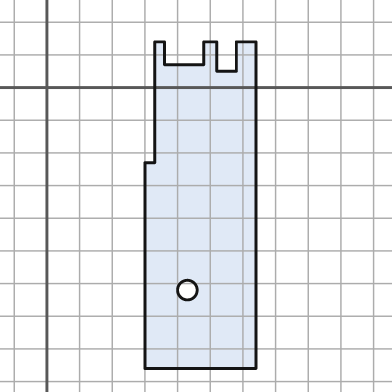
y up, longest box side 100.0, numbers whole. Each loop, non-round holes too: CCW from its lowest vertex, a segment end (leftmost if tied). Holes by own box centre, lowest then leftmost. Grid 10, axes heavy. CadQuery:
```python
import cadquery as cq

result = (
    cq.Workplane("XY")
    .moveTo(30.0, -86.0)
    .lineTo(64.0, -86.0)
    .lineTo(64.0, 14.0)
    .lineTo(58.0, 14.0)
    .lineTo(58.0, 5.0)
    .lineTo(52.0, 5.0)
    .lineTo(52.0, 14.0)
    .lineTo(48.0, 14.0)
    .lineTo(48.0, 7.0)
    .lineTo(36.0, 7.0)
    .lineTo(36.0, 14.0)
    .lineTo(33.0, 14.0)
    .lineTo(33.0, -23.0)
    .lineTo(30.0, -23.0)
    .close()
    .moveTo(43.0, -62.0)
    .circle(3.0)
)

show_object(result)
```